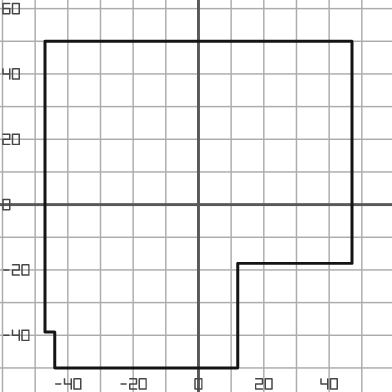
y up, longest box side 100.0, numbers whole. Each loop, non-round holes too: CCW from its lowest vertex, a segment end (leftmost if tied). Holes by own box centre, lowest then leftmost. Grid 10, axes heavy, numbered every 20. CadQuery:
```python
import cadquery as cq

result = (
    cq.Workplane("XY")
    .moveTo(-44.0, -50.0)
    .lineTo(12.0, -50.0)
    .lineTo(12.0, -18.0)
    .lineTo(47.0, -18.0)
    .lineTo(47.0, 50.0)
    .lineTo(-47.0, 50.0)
    .lineTo(-47.0, -39.0)
    .lineTo(-44.0, -39.0)
    .close()
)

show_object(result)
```